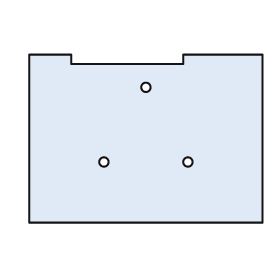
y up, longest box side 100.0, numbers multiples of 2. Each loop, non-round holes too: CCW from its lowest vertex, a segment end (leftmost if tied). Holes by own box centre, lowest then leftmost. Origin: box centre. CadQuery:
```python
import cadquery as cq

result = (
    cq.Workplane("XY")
    .moveTo(-50.0, -36.0)
    .lineTo(50.0, -36.0)
    .lineTo(50.0, 36.0)
    .lineTo(16.0, 36.0)
    .lineTo(16.0, 32.0)
    .lineTo(-32.0, 32.0)
    .lineTo(-32.0, 36.0)
    .lineTo(-50.0, 36.0)
    .close()
    .moveTo(-18.0, -10.0)
    .circle(2.0)
    .moveTo(18.0, -10.0)
    .circle(2.0)
    .moveTo(0.0, 22.0)
    .circle(2.0)
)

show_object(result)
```